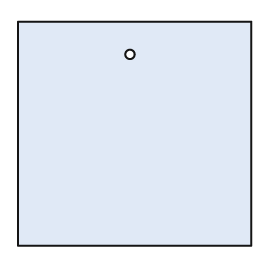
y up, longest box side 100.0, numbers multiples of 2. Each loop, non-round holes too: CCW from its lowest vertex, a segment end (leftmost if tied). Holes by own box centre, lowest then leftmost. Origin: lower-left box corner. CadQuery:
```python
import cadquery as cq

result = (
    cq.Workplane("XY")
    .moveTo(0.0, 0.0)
    .lineTo(100.0, 0.0)
    .lineTo(100.0, 96.0)
    .lineTo(0.0, 96.0)
    .close()
    .moveTo(48.0, 82.0)
    .circle(2.0)
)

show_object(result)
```